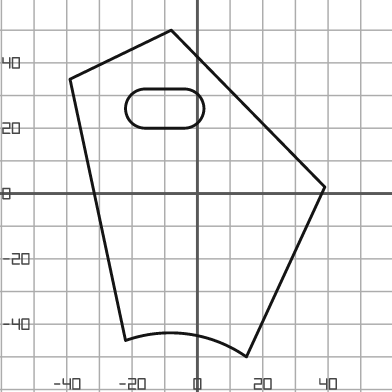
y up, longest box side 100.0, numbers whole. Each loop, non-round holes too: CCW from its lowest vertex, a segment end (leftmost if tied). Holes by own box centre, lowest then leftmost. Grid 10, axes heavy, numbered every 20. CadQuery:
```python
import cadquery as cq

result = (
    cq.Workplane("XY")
    .moveTo(15.0, -50.0)
    .lineTo(39.0, 2.0)
    .lineTo(-8.0, 50.0)
    .lineTo(-39.0, 35.0)
    .lineTo(-22.0, -45.0)
    .threePointArc((-3.0, -43.0), (15.0, -50.0))
    .close()
    .moveTo(-16.0, 20.0)
    .lineTo(-4.0, 20.0)
    .threePointArc((2.0, 26.0), (-4.0, 32.0))
    .lineTo(-16.0, 32.0)
    .threePointArc((-22.0, 26.0), (-16.0, 20.0))
    .close()
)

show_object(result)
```